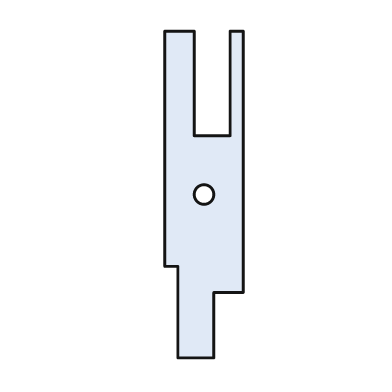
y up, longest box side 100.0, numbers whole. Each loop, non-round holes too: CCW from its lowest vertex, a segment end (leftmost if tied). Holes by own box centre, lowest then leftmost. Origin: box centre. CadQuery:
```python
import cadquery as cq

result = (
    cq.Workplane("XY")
    .moveTo(-8.0, -50.0)
    .lineTo(3.0, -50.0)
    .lineTo(3.0, -30.0)
    .lineTo(12.0, -30.0)
    .lineTo(12.0, 50.0)
    .lineTo(8.0, 50.0)
    .lineTo(8.0, 18.0)
    .lineTo(-3.0, 18.0)
    .lineTo(-3.0, 50.0)
    .lineTo(-12.0, 50.0)
    .lineTo(-12.0, -22.0)
    .lineTo(-8.0, -22.0)
    .close()
    .moveTo(0.0, 0.0)
    .circle(3.0)
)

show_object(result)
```